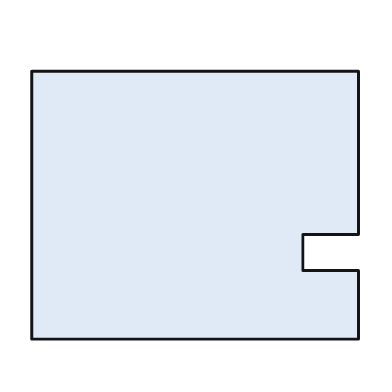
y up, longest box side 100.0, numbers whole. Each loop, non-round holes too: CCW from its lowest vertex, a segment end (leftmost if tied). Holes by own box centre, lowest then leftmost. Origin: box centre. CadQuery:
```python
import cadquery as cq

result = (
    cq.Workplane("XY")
    .moveTo(-50.0, -41.0)
    .lineTo(50.0, -41.0)
    .lineTo(50.0, -20.0)
    .lineTo(33.0, -20.0)
    .lineTo(33.0, -9.0)
    .lineTo(50.0, -9.0)
    .lineTo(50.0, 41.0)
    .lineTo(-50.0, 41.0)
    .close()
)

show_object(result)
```